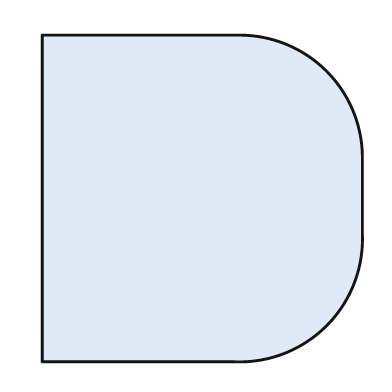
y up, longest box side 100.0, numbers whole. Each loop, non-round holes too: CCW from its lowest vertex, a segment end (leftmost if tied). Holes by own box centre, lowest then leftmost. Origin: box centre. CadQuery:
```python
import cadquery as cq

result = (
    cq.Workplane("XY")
    .moveTo(-49.0, -50.0)
    .lineTo(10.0, -50.0)
    .threePointArc((38.0, -39.0), (49.0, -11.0))
    .lineTo(49.0, 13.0)
    .threePointArc((38.0, 39.0), (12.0, 50.0))
    .lineTo(-49.0, 50.0)
    .close()
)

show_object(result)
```